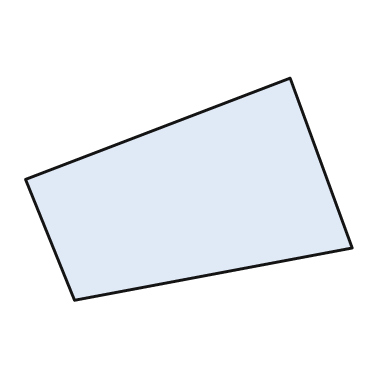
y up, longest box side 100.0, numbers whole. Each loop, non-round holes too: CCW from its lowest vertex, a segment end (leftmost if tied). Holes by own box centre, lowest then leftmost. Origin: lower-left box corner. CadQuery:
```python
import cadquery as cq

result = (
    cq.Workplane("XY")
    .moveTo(15.0, 0.0)
    .lineTo(100.0, 16.0)
    .lineTo(81.0, 68.0)
    .lineTo(0.0, 37.0)
    .close()
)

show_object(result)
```